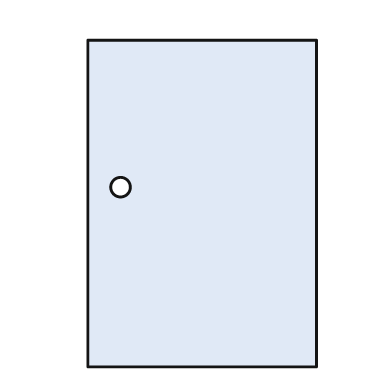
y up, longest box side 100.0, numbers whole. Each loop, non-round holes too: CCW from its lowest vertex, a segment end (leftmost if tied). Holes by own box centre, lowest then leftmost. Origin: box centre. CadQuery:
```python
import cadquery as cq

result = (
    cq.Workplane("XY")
    .moveTo(-35.0, -50.0)
    .lineTo(35.0, -50.0)
    .lineTo(35.0, 50.0)
    .lineTo(-35.0, 50.0)
    .close()
    .moveTo(-25.0, 5.0)
    .circle(3.0)
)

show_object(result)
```